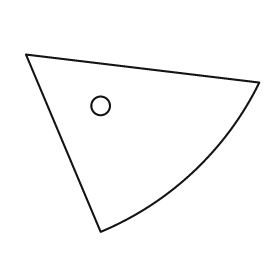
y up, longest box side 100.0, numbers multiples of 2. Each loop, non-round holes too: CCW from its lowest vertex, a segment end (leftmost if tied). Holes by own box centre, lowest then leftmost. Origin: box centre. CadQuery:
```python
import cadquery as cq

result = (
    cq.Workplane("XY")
    .moveTo(-18.0, -38.0)
    .threePointArc((22.0, -12.0), (50.0, 26.0))
    .lineTo(-50.0, 38.0)
    .close()
    .moveTo(-18.0, 16.0)
    .circle(4.0)
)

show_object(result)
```